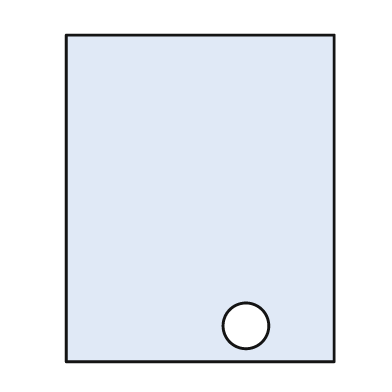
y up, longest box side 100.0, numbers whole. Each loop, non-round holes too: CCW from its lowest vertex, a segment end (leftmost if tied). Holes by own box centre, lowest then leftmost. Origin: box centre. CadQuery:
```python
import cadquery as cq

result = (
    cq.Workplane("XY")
    .moveTo(-41.0, -50.0)
    .lineTo(41.0, -50.0)
    .lineTo(41.0, 50.0)
    .lineTo(-41.0, 50.0)
    .close()
    .moveTo(14.0, -39.0)
    .circle(7.0)
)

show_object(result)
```